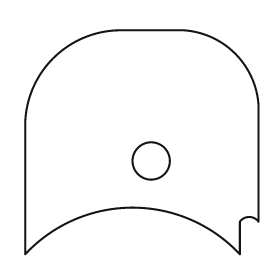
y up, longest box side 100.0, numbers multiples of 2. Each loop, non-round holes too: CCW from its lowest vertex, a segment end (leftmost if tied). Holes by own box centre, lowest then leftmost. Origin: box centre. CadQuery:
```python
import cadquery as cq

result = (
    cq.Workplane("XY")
    .moveTo(-50.0, -48.0)
    .threePointArc((-4.0, -28.0), (42.0, -48.0))
    .lineTo(42.0, -34.0)
    .threePointArc((46.0, -32.0), (50.0, -34.0))
    .lineTo(50.0, 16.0)
    .threePointArc((40.0, 38.0), (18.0, 48.0))
    .lineTo(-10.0, 48.0)
    .threePointArc((-38.0, 36.0), (-50.0, 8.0))
    .close()
    .moveTo(4.0, -8.0)
    .circle(8.0)
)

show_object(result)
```